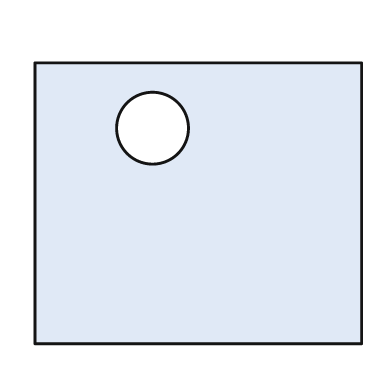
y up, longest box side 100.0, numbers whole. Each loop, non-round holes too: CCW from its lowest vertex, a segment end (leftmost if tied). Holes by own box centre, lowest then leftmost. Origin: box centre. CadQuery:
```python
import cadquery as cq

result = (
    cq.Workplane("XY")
    .moveTo(-50.0, -43.0)
    .lineTo(50.0, -43.0)
    .lineTo(50.0, 43.0)
    .lineTo(-50.0, 43.0)
    .close()
    .moveTo(-14.0, 23.0)
    .circle(11.0)
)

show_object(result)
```